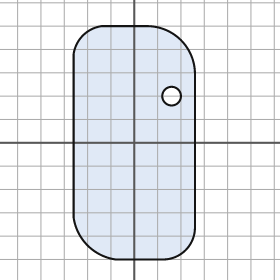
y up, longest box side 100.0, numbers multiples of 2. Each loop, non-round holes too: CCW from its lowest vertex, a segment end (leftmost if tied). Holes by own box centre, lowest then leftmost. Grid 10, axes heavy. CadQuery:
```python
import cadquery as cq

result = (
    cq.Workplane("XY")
    .moveTo(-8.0, -50.0)
    .lineTo(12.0, -50.0)
    .threePointArc((22.0, -46.0), (26.0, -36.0))
    .lineTo(26.0, 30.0)
    .threePointArc((20.0, 44.0), (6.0, 50.0))
    .lineTo(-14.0, 50.0)
    .threePointArc((-22.0, 46.0), (-26.0, 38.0))
    .lineTo(-26.0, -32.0)
    .threePointArc((-20.0, -44.0), (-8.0, -50.0))
    .close()
    .moveTo(16.0, 20.0)
    .circle(4.0)
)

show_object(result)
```